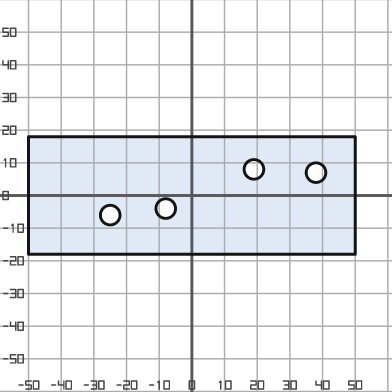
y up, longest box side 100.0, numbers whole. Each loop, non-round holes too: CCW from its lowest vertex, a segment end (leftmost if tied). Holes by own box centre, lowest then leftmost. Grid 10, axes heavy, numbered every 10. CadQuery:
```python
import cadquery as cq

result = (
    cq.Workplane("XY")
    .moveTo(-50.0, -18.0)
    .lineTo(50.0, -18.0)
    .lineTo(50.0, 18.0)
    .lineTo(-50.0, 18.0)
    .close()
    .moveTo(-25.0, -6.0)
    .circle(3.0)
    .moveTo(-8.0, -4.0)
    .circle(3.0)
    .moveTo(38.0, 7.0)
    .circle(3.0)
    .moveTo(19.0, 8.0)
    .circle(3.0)
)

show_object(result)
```